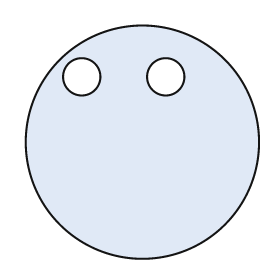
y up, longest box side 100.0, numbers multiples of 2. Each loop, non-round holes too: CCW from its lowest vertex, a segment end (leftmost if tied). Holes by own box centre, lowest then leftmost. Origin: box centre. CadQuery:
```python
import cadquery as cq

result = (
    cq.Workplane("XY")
    .moveTo(0.0, 0.0)
    .circle(50.0)
    .moveTo(-26.0, 28.0)
    .circle(8.0)
    .moveTo(10.0, 28.0)
    .circle(8.0)
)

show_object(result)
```